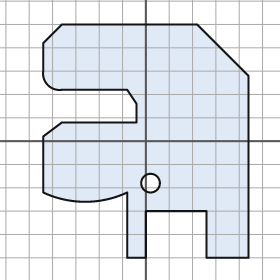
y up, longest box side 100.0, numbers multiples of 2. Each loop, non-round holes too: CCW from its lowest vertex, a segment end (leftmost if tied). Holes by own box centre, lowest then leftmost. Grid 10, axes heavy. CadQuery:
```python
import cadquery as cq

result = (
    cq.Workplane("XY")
    .moveTo(-8.0, -50.0)
    .lineTo(0.0, -50.0)
    .lineTo(0.0, -30.0)
    .lineTo(26.0, -30.0)
    .lineTo(26.0, -50.0)
    .lineTo(44.0, -50.0)
    .lineTo(44.0, 28.0)
    .lineTo(22.0, 50.0)
    .lineTo(-36.0, 50.0)
    .lineTo(-44.0, 42.0)
    .lineTo(-44.0, 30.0)
    .threePointArc((-42.0, 24.0), (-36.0, 22.0))
    .lineTo(-8.0, 22.0)
    .lineTo(-4.0, 16.0)
    .lineTo(-4.0, 8.0)
    .lineTo(-36.0, 8.0)
    .lineTo(-44.0, 2.0)
    .lineTo(-44.0, -22.0)
    .threePointArc((-26.0, -26.0), (-8.0, -22.0))
    .close()
    .moveTo(2.0, -18.0)
    .circle(4.0)
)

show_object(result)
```